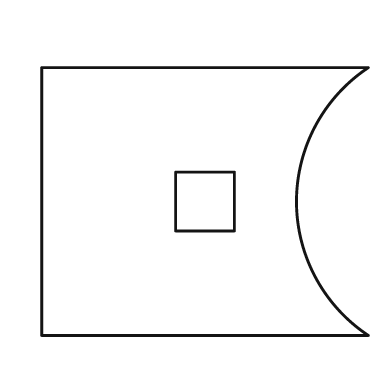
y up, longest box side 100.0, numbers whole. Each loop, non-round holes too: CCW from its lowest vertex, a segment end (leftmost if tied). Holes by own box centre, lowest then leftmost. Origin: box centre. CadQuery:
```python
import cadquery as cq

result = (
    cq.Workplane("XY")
    .moveTo(-50.0, -41.0)
    .lineTo(50.0, -41.0)
    .threePointArc((28.0, 0.0), (50.0, 41.0))
    .lineTo(-50.0, 41.0)
    .close()
    .moveTo(-9.0, -9.0)
    .lineTo(9.0, -9.0)
    .lineTo(9.0, 9.0)
    .lineTo(-9.0, 9.0)
    .close()
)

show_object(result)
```